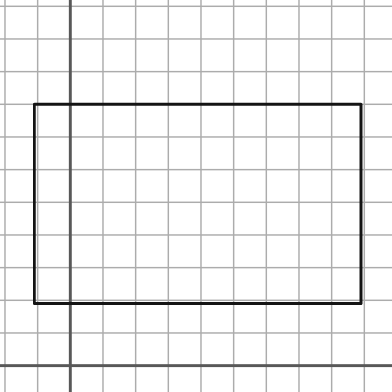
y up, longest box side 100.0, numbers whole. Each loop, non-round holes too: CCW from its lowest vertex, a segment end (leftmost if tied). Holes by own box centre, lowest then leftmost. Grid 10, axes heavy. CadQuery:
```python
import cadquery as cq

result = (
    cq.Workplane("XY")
    .moveTo(-11.0, 19.0)
    .lineTo(89.0, 19.0)
    .lineTo(89.0, 80.0)
    .lineTo(-11.0, 80.0)
    .close()
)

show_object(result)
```